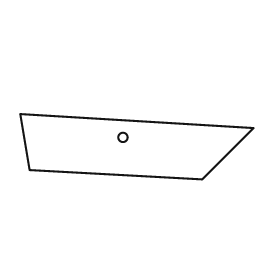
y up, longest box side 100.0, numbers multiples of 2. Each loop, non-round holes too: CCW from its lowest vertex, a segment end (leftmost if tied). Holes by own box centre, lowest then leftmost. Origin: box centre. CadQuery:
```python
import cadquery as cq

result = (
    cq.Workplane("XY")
    .moveTo(28.0, -14.0)
    .lineTo(50.0, 8.0)
    .lineTo(-50.0, 14.0)
    .lineTo(-46.0, -10.0)
    .close()
    .moveTo(-6.0, 4.0)
    .circle(2.0)
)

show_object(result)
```